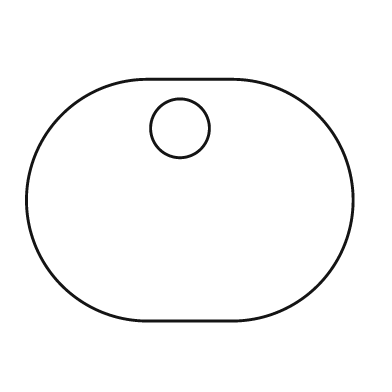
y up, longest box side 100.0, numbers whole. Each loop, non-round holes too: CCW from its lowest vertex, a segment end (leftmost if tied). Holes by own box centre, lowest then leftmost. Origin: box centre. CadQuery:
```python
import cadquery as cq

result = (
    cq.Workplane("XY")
    .moveTo(-13.0, -37.0)
    .lineTo(13.0, -37.0)
    .threePointArc((50.0, 0.0), (13.0, 37.0))
    .lineTo(-13.0, 37.0)
    .threePointArc((-50.0, 0.0), (-13.0, -37.0))
    .close()
    .moveTo(-3.0, 22.0)
    .circle(9.0)
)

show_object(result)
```